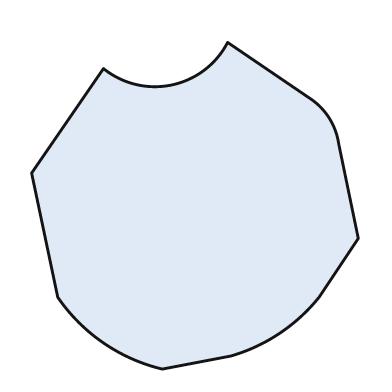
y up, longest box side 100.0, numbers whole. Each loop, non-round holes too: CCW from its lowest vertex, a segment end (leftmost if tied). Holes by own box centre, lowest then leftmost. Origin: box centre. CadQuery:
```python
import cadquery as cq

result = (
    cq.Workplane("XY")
    .moveTo(-10.0, -50.0)
    .lineTo(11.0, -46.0)
    .threePointArc((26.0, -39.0), (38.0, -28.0))
    .lineTo(50.0, -10.0)
    .lineTo(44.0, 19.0)
    .threePointArc((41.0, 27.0), (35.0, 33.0))
    .lineTo(10.0, 50.0)
    .threePointArc((-7.0, 37.0), (-28.0, 42.0))
    .lineTo(-50.0, 10.0)
    .lineTo(-42.0, -28.0)
    .threePointArc((-28.0, -42.0), (-10.0, -50.0))
    .close()
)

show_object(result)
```